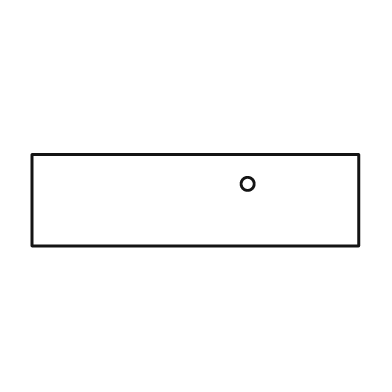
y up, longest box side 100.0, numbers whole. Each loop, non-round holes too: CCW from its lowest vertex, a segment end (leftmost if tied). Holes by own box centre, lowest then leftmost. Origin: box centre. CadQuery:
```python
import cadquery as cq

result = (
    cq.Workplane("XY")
    .moveTo(-50.0, -14.0)
    .lineTo(50.0, -14.0)
    .lineTo(50.0, 14.0)
    .lineTo(-50.0, 14.0)
    .close()
    .moveTo(16.0, 5.0)
    .circle(2.0)
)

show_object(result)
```